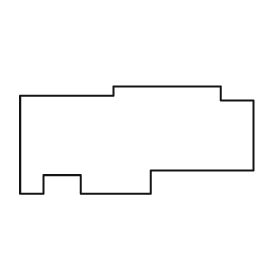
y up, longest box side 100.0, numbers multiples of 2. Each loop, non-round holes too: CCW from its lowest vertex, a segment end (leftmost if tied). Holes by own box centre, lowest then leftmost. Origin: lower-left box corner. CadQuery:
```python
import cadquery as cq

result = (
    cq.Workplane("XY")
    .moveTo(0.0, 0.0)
    .lineTo(10.0, 0.0)
    .lineTo(10.0, 8.0)
    .lineTo(26.0, 8.0)
    .lineTo(26.0, 0.0)
    .lineTo(56.0, 0.0)
    .lineTo(56.0, 10.0)
    .lineTo(100.0, 10.0)
    .lineTo(100.0, 40.0)
    .lineTo(86.0, 40.0)
    .lineTo(86.0, 46.0)
    .lineTo(40.0, 46.0)
    .lineTo(40.0, 42.0)
    .lineTo(0.0, 42.0)
    .close()
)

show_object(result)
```